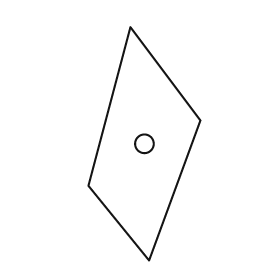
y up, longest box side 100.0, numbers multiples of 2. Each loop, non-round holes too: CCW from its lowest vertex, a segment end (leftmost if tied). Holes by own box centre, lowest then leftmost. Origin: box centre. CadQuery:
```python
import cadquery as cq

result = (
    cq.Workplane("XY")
    .moveTo(2.0, -50.0)
    .lineTo(24.0, 10.0)
    .lineTo(-6.0, 50.0)
    .lineTo(-24.0, -18.0)
    .close()
    .moveTo(0.0, 0.0)
    .circle(4.0)
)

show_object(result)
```